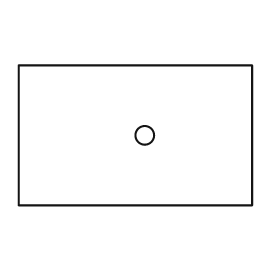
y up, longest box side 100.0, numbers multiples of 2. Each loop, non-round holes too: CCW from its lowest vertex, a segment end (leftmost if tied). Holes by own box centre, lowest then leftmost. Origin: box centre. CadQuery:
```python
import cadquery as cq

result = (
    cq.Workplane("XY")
    .moveTo(-50.0, -30.0)
    .lineTo(50.0, -30.0)
    .lineTo(50.0, 30.0)
    .lineTo(-50.0, 30.0)
    .close()
    .moveTo(4.0, 0.0)
    .circle(4.0)
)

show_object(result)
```